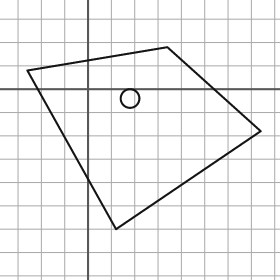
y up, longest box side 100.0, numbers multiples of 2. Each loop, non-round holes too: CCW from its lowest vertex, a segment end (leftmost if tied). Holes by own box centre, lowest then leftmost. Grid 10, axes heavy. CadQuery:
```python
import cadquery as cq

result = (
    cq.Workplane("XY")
    .moveTo(12.0, -60.0)
    .lineTo(74.0, -18.0)
    .lineTo(34.0, 18.0)
    .lineTo(-26.0, 8.0)
    .close()
    .moveTo(18.0, -4.0)
    .circle(4.0)
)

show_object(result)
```